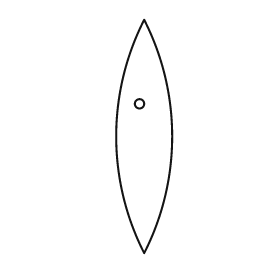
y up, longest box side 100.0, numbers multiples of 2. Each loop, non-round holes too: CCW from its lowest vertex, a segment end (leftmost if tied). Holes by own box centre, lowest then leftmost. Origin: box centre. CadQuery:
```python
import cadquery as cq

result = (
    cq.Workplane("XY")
    .moveTo(0.0, -50.0)
    .threePointArc((12.0, 0.0), (0.0, 50.0))
    .threePointArc((-12.0, 0.0), (0.0, -50.0))
    .close()
    .moveTo(-2.0, 14.0)
    .circle(2.0)
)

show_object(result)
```